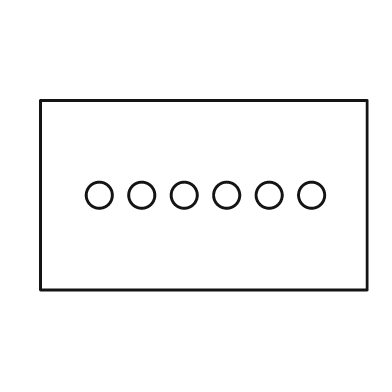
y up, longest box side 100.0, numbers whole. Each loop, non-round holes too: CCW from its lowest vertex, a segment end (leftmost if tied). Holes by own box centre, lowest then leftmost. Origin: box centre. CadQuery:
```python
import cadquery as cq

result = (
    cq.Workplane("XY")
    .moveTo(-50.0, -29.0)
    .lineTo(50.0, -29.0)
    .lineTo(50.0, 29.0)
    .lineTo(-50.0, 29.0)
    .close()
    .moveTo(-32.0, 0.0)
    .circle(4.0)
    .moveTo(-19.0, 0.0)
    .circle(4.0)
    .moveTo(-6.0, 0.0)
    .circle(4.0)
    .moveTo(7.0, 0.0)
    .circle(4.0)
    .moveTo(20.0, 0.0)
    .circle(4.0)
    .moveTo(33.0, 0.0)
    .circle(4.0)
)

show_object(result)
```